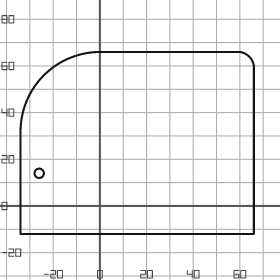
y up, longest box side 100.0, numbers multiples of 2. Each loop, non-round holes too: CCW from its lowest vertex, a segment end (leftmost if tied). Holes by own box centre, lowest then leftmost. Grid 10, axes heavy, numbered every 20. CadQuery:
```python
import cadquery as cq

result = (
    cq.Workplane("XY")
    .moveTo(-34.0, -12.0)
    .lineTo(66.0, -12.0)
    .lineTo(66.0, 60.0)
    .threePointArc((64.0, 64.0), (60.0, 66.0))
    .lineTo(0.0, 66.0)
    .threePointArc((-24.0, 56.0), (-34.0, 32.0))
    .close()
    .moveTo(-26.0, 14.0)
    .circle(2.0)
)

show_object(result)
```